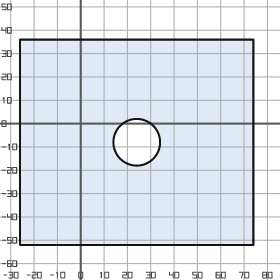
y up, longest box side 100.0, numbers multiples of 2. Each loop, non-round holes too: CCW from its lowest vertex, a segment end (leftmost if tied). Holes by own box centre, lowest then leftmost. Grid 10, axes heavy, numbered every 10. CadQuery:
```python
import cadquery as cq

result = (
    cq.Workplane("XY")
    .moveTo(-26.0, -52.0)
    .lineTo(74.0, -52.0)
    .lineTo(74.0, 36.0)
    .lineTo(-26.0, 36.0)
    .close()
    .moveTo(24.0, -8.0)
    .circle(10.0)
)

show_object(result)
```